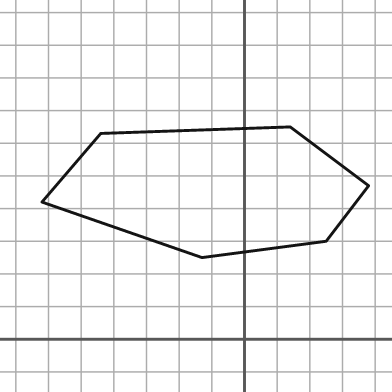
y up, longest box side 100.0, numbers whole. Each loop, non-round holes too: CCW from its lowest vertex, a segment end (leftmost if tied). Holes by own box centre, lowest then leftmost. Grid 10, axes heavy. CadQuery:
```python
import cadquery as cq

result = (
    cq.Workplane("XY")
    .moveTo(-13.0, 25.0)
    .lineTo(25.0, 30.0)
    .lineTo(38.0, 47.0)
    .lineTo(14.0, 65.0)
    .lineTo(-44.0, 63.0)
    .lineTo(-62.0, 42.0)
    .close()
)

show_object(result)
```